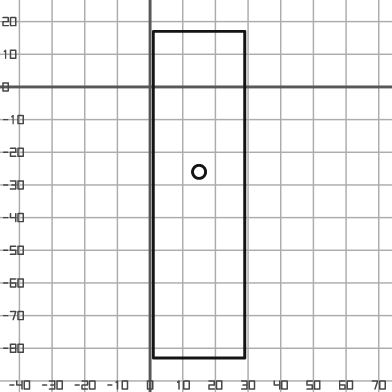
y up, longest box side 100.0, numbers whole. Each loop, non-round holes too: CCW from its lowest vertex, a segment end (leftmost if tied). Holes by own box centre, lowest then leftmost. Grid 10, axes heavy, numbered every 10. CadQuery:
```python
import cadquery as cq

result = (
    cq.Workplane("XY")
    .moveTo(1.0, -83.0)
    .lineTo(29.0, -83.0)
    .lineTo(29.0, 17.0)
    .lineTo(1.0, 17.0)
    .close()
    .moveTo(15.0, -26.0)
    .circle(2.0)
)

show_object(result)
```